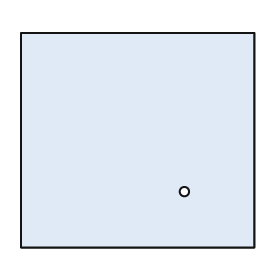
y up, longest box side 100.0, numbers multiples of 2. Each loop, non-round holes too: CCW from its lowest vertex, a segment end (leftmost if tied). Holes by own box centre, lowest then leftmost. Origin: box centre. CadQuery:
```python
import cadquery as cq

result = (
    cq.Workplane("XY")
    .moveTo(-50.0, -46.0)
    .lineTo(50.0, -46.0)
    .lineTo(50.0, 46.0)
    .lineTo(-50.0, 46.0)
    .close()
    .moveTo(20.0, -22.0)
    .circle(2.0)
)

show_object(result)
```